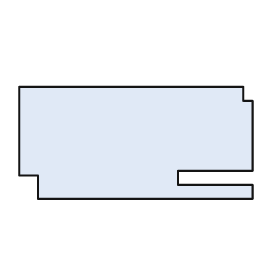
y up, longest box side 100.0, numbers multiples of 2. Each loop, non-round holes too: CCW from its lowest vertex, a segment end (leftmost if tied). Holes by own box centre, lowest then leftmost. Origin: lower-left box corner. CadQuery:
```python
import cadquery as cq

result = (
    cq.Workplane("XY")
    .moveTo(8.0, 0.0)
    .lineTo(100.0, 0.0)
    .lineTo(100.0, 6.0)
    .lineTo(68.0, 6.0)
    .lineTo(68.0, 12.0)
    .lineTo(100.0, 12.0)
    .lineTo(100.0, 42.0)
    .lineTo(96.0, 42.0)
    .lineTo(96.0, 48.0)
    .lineTo(0.0, 48.0)
    .lineTo(0.0, 10.0)
    .lineTo(8.0, 10.0)
    .close()
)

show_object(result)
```